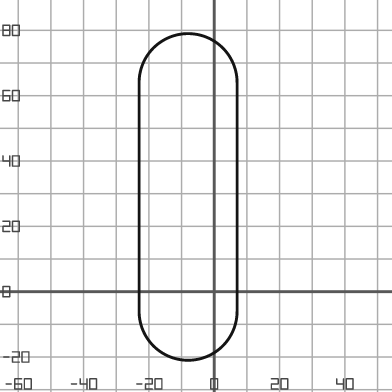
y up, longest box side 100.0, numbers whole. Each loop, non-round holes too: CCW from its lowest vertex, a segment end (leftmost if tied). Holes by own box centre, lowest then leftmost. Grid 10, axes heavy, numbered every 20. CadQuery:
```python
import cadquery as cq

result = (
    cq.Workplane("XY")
    .moveTo(-23.0, -6.0)
    .threePointArc((-8.0, -21.0), (7.0, -6.0))
    .lineTo(7.0, 64.0)
    .threePointArc((-8.0, 79.0), (-23.0, 64.0))
    .close()
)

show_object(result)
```